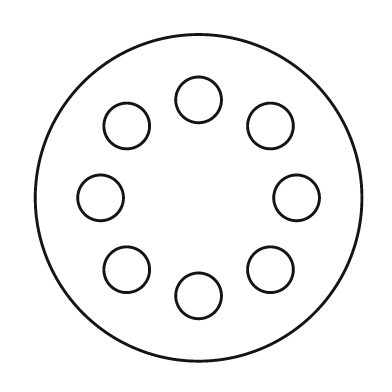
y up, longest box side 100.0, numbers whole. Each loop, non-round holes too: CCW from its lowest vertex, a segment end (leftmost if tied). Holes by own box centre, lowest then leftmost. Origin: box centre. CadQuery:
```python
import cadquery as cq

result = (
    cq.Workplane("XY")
    .moveTo(0.0, 0.0)
    .circle(50.0)
    .moveTo(0.0, -30.0)
    .circle(7.0)
    .moveTo(-22.0, -22.0)
    .circle(7.0)
    .moveTo(22.0, -22.0)
    .circle(7.0)
    .moveTo(-30.0, 0.0)
    .circle(7.0)
    .moveTo(30.0, 0.0)
    .circle(7.0)
    .moveTo(-22.0, 22.0)
    .circle(7.0)
    .moveTo(22.0, 22.0)
    .circle(7.0)
    .moveTo(0.0, 30.0)
    .circle(7.0)
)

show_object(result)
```